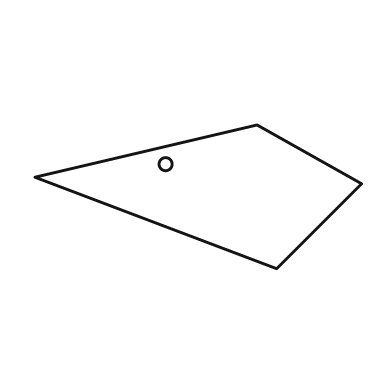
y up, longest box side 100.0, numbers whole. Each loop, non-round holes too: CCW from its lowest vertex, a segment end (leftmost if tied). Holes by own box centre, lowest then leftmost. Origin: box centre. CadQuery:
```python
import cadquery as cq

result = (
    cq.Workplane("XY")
    .moveTo(24.0, -22.0)
    .lineTo(50.0, 4.0)
    .lineTo(18.0, 22.0)
    .lineTo(-50.0, 6.0)
    .close()
    .moveTo(-10.0, 10.0)
    .circle(2.0)
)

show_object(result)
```